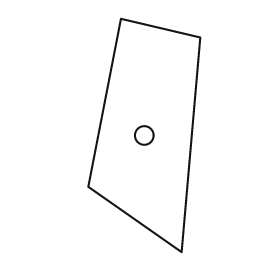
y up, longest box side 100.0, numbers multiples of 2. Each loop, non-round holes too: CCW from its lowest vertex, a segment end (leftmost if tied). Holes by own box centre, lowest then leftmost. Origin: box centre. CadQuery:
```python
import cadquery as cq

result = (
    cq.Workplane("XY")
    .moveTo(16.0, -50.0)
    .lineTo(24.0, 42.0)
    .lineTo(-10.0, 50.0)
    .lineTo(-24.0, -22.0)
    .close()
    .moveTo(0.0, 0.0)
    .circle(4.0)
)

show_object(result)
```